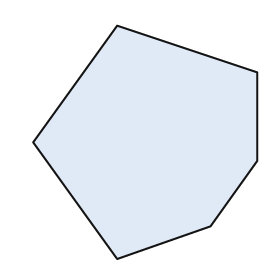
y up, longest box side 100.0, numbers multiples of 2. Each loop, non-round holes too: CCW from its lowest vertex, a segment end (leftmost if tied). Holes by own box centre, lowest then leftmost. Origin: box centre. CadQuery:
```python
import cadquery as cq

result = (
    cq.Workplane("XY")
    .moveTo(-12.0, -50.0)
    .lineTo(28.0, -36.0)
    .lineTo(48.0, -8.0)
    .lineTo(48.0, 30.0)
    .lineTo(-12.0, 50.0)
    .lineTo(-48.0, 0.0)
    .close()
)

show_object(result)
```